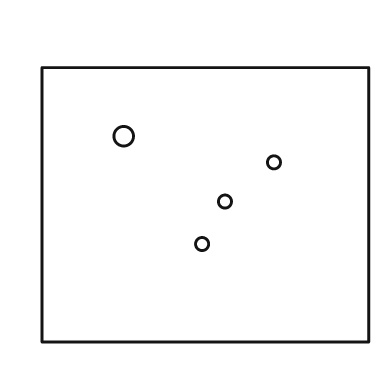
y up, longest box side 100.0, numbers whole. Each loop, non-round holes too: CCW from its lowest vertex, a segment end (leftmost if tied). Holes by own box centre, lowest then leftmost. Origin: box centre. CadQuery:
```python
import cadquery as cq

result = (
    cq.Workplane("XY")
    .moveTo(-50.0, -42.0)
    .lineTo(50.0, -42.0)
    .lineTo(50.0, 42.0)
    .lineTo(-50.0, 42.0)
    .close()
    .moveTo(-1.0, -12.0)
    .circle(2.0)
    .moveTo(6.0, 1.0)
    .circle(2.0)
    .moveTo(21.0, 13.0)
    .circle(2.0)
    .moveTo(-25.0, 21.0)
    .circle(3.0)
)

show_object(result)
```